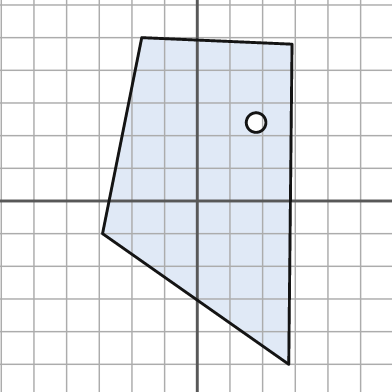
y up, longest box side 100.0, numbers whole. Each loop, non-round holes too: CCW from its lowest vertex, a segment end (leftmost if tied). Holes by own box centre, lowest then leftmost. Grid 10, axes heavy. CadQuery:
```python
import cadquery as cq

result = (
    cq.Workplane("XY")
    .moveTo(28.0, -50.0)
    .lineTo(29.0, 48.0)
    .lineTo(-17.0, 50.0)
    .lineTo(-29.0, -10.0)
    .close()
    .moveTo(18.0, 24.0)
    .circle(3.0)
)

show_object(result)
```